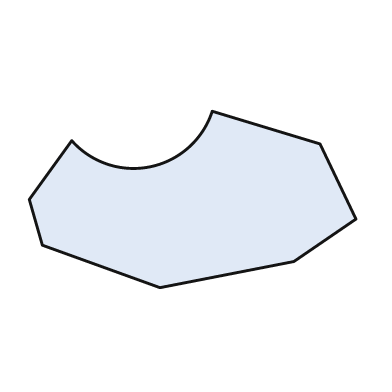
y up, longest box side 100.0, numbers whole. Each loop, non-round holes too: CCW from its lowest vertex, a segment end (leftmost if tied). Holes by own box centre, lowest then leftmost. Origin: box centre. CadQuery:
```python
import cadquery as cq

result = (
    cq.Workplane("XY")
    .moveTo(-10.0, -27.0)
    .lineTo(31.0, -19.0)
    .lineTo(50.0, -6.0)
    .lineTo(39.0, 17.0)
    .lineTo(6.0, 27.0)
    .threePointArc((-13.0, 10.0), (-37.0, 18.0))
    .lineTo(-50.0, 0.0)
    .lineTo(-46.0, -14.0)
    .close()
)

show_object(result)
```